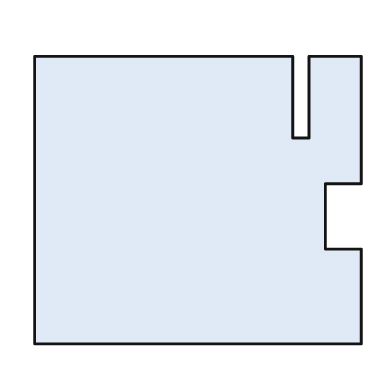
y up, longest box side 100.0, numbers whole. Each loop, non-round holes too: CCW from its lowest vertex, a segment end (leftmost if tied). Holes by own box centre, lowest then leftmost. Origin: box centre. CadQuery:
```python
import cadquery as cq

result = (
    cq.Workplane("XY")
    .moveTo(-50.0, -44.0)
    .lineTo(50.0, -44.0)
    .lineTo(50.0, -15.0)
    .lineTo(39.0, -15.0)
    .lineTo(39.0, 5.0)
    .lineTo(50.0, 5.0)
    .lineTo(50.0, 44.0)
    .lineTo(34.0, 44.0)
    .lineTo(34.0, 19.0)
    .lineTo(29.0, 19.0)
    .lineTo(29.0, 44.0)
    .lineTo(-50.0, 44.0)
    .close()
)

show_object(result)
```